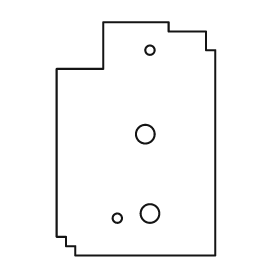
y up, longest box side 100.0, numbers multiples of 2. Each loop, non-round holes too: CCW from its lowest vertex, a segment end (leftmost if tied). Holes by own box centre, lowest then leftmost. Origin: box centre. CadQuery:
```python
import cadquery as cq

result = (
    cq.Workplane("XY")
    .moveTo(-26.0, -50.0)
    .lineTo(34.0, -50.0)
    .lineTo(34.0, 38.0)
    .lineTo(30.0, 38.0)
    .lineTo(30.0, 46.0)
    .lineTo(14.0, 46.0)
    .lineTo(14.0, 50.0)
    .lineTo(-14.0, 50.0)
    .lineTo(-14.0, 30.0)
    .lineTo(-34.0, 30.0)
    .lineTo(-34.0, -42.0)
    .lineTo(-30.0, -42.0)
    .lineTo(-30.0, -46.0)
    .lineTo(-26.0, -46.0)
    .close()
    .moveTo(-8.0, -34.0)
    .circle(2.0)
    .moveTo(6.0, -32.0)
    .circle(4.0)
    .moveTo(4.0, 2.0)
    .circle(4.0)
    .moveTo(6.0, 38.0)
    .circle(2.0)
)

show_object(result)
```